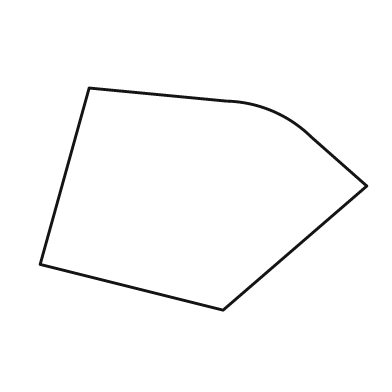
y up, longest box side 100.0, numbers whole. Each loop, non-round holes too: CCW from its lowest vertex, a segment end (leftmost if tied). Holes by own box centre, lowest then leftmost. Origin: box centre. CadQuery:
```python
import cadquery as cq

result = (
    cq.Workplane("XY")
    .moveTo(6.0, -34.0)
    .lineTo(50.0, 4.0)
    .lineTo(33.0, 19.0)
    .threePointArc((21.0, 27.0), (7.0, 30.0))
    .lineTo(-35.0, 34.0)
    .lineTo(-50.0, -20.0)
    .close()
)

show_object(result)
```